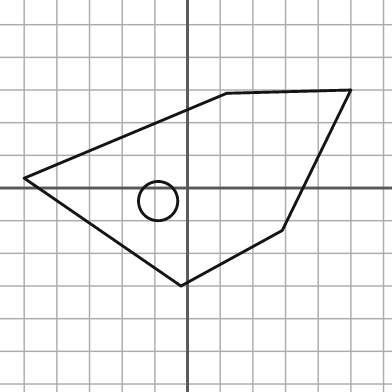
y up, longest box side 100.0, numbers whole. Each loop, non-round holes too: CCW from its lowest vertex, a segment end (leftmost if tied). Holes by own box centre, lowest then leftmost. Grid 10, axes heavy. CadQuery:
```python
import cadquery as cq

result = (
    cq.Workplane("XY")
    .moveTo(-2.0, -30.0)
    .lineTo(29.0, -13.0)
    .lineTo(50.0, 30.0)
    .lineTo(12.0, 29.0)
    .lineTo(-50.0, 3.0)
    .close()
    .moveTo(-9.0, -4.0)
    .circle(6.0)
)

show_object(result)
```